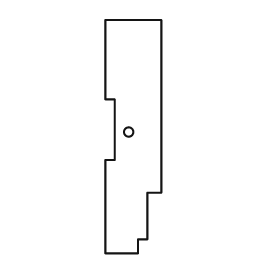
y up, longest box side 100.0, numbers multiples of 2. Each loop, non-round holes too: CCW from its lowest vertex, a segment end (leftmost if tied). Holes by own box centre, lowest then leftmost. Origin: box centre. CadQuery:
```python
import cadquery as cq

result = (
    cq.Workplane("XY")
    .moveTo(-12.0, -50.0)
    .lineTo(2.0, -50.0)
    .lineTo(2.0, -44.0)
    .lineTo(6.0, -44.0)
    .lineTo(6.0, -24.0)
    .lineTo(12.0, -24.0)
    .lineTo(12.0, 50.0)
    .lineTo(-12.0, 50.0)
    .lineTo(-12.0, 16.0)
    .lineTo(-8.0, 16.0)
    .lineTo(-8.0, -10.0)
    .lineTo(-12.0, -10.0)
    .close()
    .moveTo(-2.0, 2.0)
    .circle(2.0)
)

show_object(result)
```